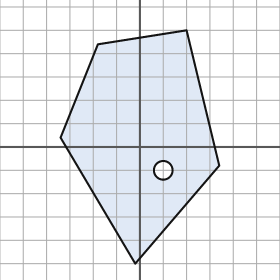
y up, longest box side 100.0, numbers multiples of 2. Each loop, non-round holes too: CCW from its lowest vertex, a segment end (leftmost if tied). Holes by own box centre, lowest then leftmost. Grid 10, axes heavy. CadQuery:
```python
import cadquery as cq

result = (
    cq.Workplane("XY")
    .moveTo(-2.0, -50.0)
    .lineTo(34.0, -8.0)
    .lineTo(20.0, 50.0)
    .lineTo(-18.0, 44.0)
    .lineTo(-34.0, 4.0)
    .close()
    .moveTo(10.0, -10.0)
    .circle(4.0)
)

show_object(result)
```